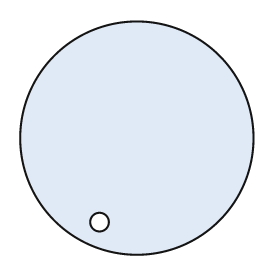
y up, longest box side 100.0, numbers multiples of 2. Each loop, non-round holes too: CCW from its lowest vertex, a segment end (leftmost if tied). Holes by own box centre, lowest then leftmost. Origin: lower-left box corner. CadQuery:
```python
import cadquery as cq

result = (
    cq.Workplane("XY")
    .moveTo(50.0, 50.0)
    .circle(50.0)
    .moveTo(34.0, 14.0)
    .circle(4.0)
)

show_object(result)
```